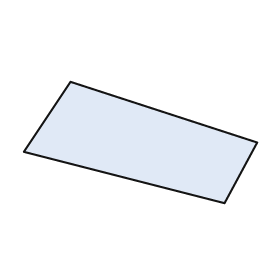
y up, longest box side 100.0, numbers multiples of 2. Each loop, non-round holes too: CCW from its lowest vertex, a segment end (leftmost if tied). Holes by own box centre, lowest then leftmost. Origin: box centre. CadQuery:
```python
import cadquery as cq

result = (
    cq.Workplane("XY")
    .moveTo(36.0, -26.0)
    .lineTo(50.0, 0.0)
    .lineTo(-30.0, 26.0)
    .lineTo(-50.0, -4.0)
    .close()
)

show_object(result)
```